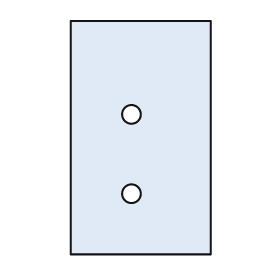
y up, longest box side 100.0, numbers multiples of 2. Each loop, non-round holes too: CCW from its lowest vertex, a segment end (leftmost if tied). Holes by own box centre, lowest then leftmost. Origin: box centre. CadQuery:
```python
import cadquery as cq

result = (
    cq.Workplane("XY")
    .moveTo(-30.0, -50.0)
    .lineTo(30.0, -50.0)
    .lineTo(30.0, 50.0)
    .lineTo(-30.0, 50.0)
    .close()
    .moveTo(-4.0, -24.0)
    .circle(4.0)
    .moveTo(-4.0, 10.0)
    .circle(4.0)
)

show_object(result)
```